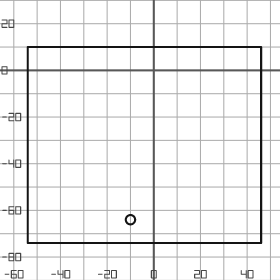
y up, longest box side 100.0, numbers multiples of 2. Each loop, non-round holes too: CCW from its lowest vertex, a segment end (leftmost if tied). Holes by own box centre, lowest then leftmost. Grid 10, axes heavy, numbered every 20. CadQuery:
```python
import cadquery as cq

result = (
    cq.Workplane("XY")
    .moveTo(-54.0, -74.0)
    .lineTo(46.0, -74.0)
    .lineTo(46.0, 10.0)
    .lineTo(-54.0, 10.0)
    .close()
    .moveTo(-10.0, -64.0)
    .circle(2.0)
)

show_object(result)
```